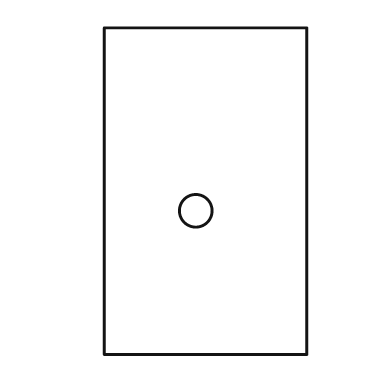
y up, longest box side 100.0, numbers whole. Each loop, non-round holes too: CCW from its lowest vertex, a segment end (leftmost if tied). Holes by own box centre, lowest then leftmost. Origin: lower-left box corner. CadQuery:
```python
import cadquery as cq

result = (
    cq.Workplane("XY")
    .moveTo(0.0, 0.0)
    .lineTo(62.0, 0.0)
    .lineTo(62.0, 100.0)
    .lineTo(0.0, 100.0)
    .close()
    .moveTo(28.0, 44.0)
    .circle(5.0)
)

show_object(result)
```